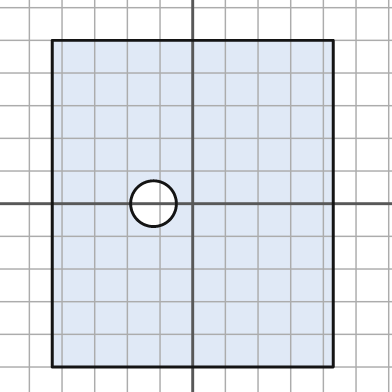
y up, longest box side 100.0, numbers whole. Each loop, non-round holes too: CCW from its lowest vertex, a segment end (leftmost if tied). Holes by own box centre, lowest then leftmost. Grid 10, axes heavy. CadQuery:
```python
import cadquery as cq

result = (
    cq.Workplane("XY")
    .moveTo(-43.0, -50.0)
    .lineTo(43.0, -50.0)
    .lineTo(43.0, 50.0)
    .lineTo(-43.0, 50.0)
    .close()
    .moveTo(-12.0, 0.0)
    .circle(7.0)
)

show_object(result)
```